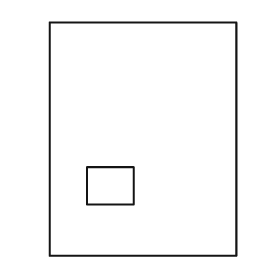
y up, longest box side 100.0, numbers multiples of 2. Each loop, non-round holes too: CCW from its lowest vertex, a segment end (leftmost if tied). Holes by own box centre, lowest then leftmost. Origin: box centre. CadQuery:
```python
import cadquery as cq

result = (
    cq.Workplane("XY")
    .moveTo(-40.0, -50.0)
    .lineTo(40.0, -50.0)
    .lineTo(40.0, 50.0)
    .lineTo(-40.0, 50.0)
    .close()
    .moveTo(-24.0, -28.0)
    .lineTo(-4.0, -28.0)
    .lineTo(-4.0, -12.0)
    .lineTo(-24.0, -12.0)
    .close()
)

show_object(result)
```